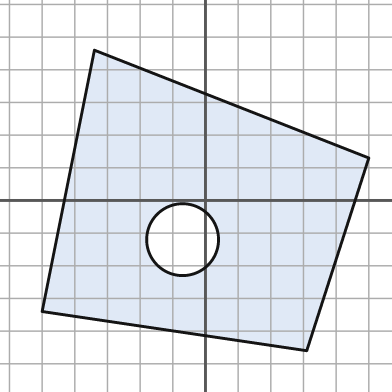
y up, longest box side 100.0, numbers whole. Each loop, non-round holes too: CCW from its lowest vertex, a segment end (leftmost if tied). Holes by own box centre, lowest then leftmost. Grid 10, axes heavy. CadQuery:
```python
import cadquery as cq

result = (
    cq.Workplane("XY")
    .moveTo(31.0, -46.0)
    .lineTo(50.0, 13.0)
    .lineTo(-34.0, 46.0)
    .lineTo(-50.0, -34.0)
    .close()
    .moveTo(-7.0, -12.0)
    .circle(11.0)
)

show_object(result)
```